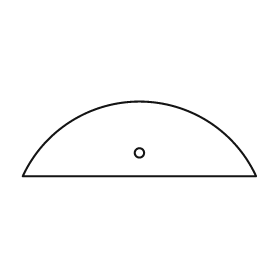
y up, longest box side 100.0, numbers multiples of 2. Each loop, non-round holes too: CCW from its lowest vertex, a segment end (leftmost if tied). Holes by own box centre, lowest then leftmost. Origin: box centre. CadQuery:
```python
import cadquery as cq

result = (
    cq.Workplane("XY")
    .moveTo(-50.0, -16.0)
    .lineTo(50.0, -16.0)
    .threePointArc((0.0, 16.0), (-50.0, -16.0))
    .close()
    .moveTo(0.0, -6.0)
    .circle(2.0)
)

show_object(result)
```